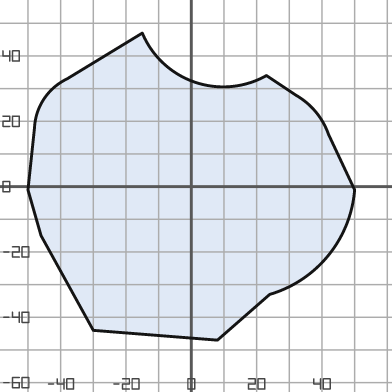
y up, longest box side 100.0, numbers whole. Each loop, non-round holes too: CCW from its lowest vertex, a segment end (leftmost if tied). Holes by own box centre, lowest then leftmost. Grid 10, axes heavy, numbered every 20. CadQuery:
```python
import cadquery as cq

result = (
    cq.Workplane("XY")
    .moveTo(8.0, -47.0)
    .lineTo(24.0, -33.0)
    .threePointArc((42.0, -21.0), (50.0, -1.0))
    .lineTo(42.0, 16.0)
    .threePointArc((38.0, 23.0), (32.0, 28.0))
    .lineTo(23.0, 34.0)
    .threePointArc((1.0, 32.0), (-15.0, 47.0))
    .lineTo(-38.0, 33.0)
    .threePointArc((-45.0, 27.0), (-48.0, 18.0))
    .lineTo(-50.0, -1.0)
    .lineTo(-46.0, -15.0)
    .lineTo(-30.0, -44.0)
    .close()
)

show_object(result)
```